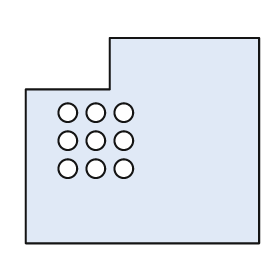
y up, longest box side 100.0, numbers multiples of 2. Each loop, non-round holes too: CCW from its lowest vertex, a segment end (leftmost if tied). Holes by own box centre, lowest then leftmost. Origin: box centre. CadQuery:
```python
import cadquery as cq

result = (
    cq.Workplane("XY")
    .moveTo(-50.0, -44.0)
    .lineTo(50.0, -44.0)
    .lineTo(50.0, 44.0)
    .lineTo(-14.0, 44.0)
    .lineTo(-14.0, 22.0)
    .lineTo(-50.0, 22.0)
    .close()
    .moveTo(-32.0, -12.0)
    .circle(4.0)
    .moveTo(-20.0, -12.0)
    .circle(4.0)
    .moveTo(-8.0, -12.0)
    .circle(4.0)
    .moveTo(-32.0, 0.0)
    .circle(4.0)
    .moveTo(-20.0, 0.0)
    .circle(4.0)
    .moveTo(-8.0, 0.0)
    .circle(4.0)
    .moveTo(-32.0, 12.0)
    .circle(4.0)
    .moveTo(-20.0, 12.0)
    .circle(4.0)
    .moveTo(-8.0, 12.0)
    .circle(4.0)
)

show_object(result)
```